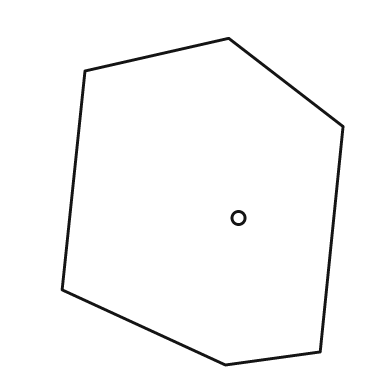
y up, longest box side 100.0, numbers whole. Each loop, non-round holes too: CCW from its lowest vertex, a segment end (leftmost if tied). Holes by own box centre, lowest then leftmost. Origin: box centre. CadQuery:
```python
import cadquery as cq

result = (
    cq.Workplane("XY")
    .moveTo(7.0, -50.0)
    .lineTo(36.0, -46.0)
    .lineTo(43.0, 23.0)
    .lineTo(8.0, 50.0)
    .lineTo(-36.0, 40.0)
    .lineTo(-43.0, -27.0)
    .close()
    .moveTo(11.0, -5.0)
    .circle(2.0)
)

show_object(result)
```